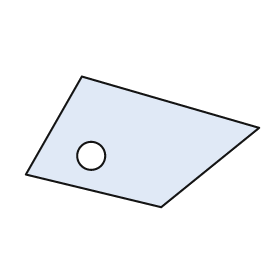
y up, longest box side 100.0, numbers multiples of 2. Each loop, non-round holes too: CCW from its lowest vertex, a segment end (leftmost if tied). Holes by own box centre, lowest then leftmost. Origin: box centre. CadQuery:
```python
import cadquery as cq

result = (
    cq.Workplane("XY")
    .moveTo(8.0, -28.0)
    .lineTo(50.0, 6.0)
    .lineTo(-26.0, 28.0)
    .lineTo(-50.0, -14.0)
    .close()
    .moveTo(-22.0, -6.0)
    .circle(6.0)
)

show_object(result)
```